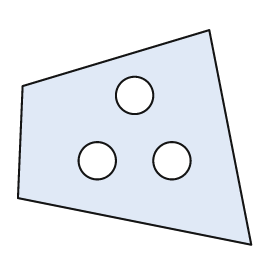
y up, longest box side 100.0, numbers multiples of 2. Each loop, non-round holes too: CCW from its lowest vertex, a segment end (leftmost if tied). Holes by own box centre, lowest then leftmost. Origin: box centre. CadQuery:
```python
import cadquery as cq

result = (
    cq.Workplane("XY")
    .moveTo(50.0, -46.0)
    .lineTo(32.0, 46.0)
    .lineTo(-48.0, 22.0)
    .lineTo(-50.0, -26.0)
    .close()
    .moveTo(-16.0, -10.0)
    .circle(8.0)
    .moveTo(16.0, -10.0)
    .circle(8.0)
    .moveTo(0.0, 18.0)
    .circle(8.0)
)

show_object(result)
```